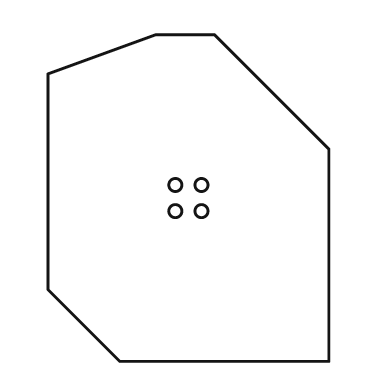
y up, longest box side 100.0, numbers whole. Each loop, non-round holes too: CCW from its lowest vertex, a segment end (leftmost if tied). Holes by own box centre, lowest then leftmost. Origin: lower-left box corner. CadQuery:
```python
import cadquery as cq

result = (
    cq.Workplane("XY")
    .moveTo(22.0, 0.0)
    .lineTo(86.0, 0.0)
    .lineTo(86.0, 65.0)
    .lineTo(51.0, 100.0)
    .lineTo(33.0, 100.0)
    .lineTo(0.0, 88.0)
    .lineTo(0.0, 22.0)
    .close()
    .moveTo(39.0, 46.0)
    .circle(2.0)
    .moveTo(47.0, 46.0)
    .circle(2.0)
    .moveTo(39.0, 54.0)
    .circle(2.0)
    .moveTo(47.0, 54.0)
    .circle(2.0)
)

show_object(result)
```